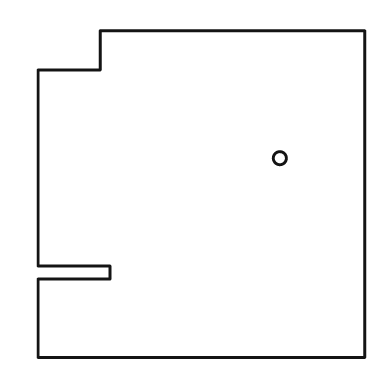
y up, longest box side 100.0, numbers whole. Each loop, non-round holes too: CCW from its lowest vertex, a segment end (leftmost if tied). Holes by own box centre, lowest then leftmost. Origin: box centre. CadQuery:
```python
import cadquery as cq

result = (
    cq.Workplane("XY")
    .moveTo(-50.0, -50.0)
    .lineTo(50.0, -50.0)
    .lineTo(50.0, 50.0)
    .lineTo(-31.0, 50.0)
    .lineTo(-31.0, 38.0)
    .lineTo(-50.0, 38.0)
    .lineTo(-50.0, -22.0)
    .lineTo(-28.0, -22.0)
    .lineTo(-28.0, -26.0)
    .lineTo(-50.0, -26.0)
    .close()
    .moveTo(24.0, 11.0)
    .circle(2.0)
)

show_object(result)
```